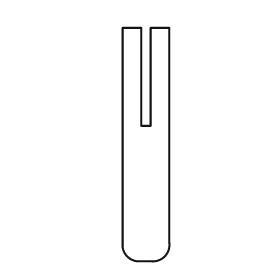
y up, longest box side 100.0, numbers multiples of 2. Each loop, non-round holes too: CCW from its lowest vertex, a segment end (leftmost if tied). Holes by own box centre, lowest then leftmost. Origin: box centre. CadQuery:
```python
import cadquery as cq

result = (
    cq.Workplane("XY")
    .moveTo(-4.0, -50.0)
    .lineTo(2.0, -50.0)
    .threePointArc((8.0, -48.0), (10.0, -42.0))
    .lineTo(10.0, 50.0)
    .lineTo(2.0, 50.0)
    .lineTo(2.0, 8.0)
    .lineTo(-2.0, 8.0)
    .lineTo(-2.0, 50.0)
    .lineTo(-10.0, 50.0)
    .lineTo(-10.0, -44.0)
    .threePointArc((-8.0, -48.0), (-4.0, -50.0))
    .close()
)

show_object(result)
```